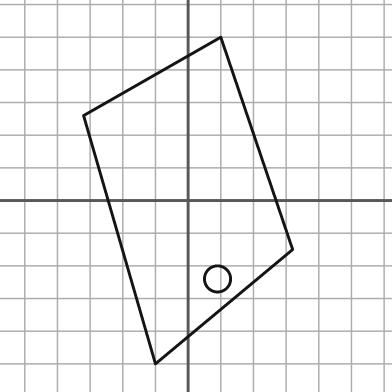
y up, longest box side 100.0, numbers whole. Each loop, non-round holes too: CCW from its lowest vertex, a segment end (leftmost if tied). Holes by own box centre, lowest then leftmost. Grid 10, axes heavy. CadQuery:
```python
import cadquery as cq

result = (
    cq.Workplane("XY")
    .moveTo(-10.0, -50.0)
    .lineTo(32.0, -15.0)
    .lineTo(10.0, 50.0)
    .lineTo(-32.0, 26.0)
    .close()
    .moveTo(9.0, -24.0)
    .circle(4.0)
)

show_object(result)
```